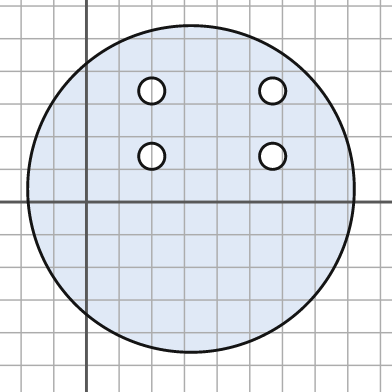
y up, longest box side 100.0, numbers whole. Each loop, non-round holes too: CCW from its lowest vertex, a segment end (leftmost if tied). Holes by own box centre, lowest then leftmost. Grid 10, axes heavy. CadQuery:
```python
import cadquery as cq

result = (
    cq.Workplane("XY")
    .moveTo(32.0, 4.0)
    .circle(50.0)
    .moveTo(20.0, 14.0)
    .circle(4.0)
    .moveTo(57.0, 14.0)
    .circle(4.0)
    .moveTo(20.0, 34.0)
    .circle(4.0)
    .moveTo(57.0, 34.0)
    .circle(4.0)
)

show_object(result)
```